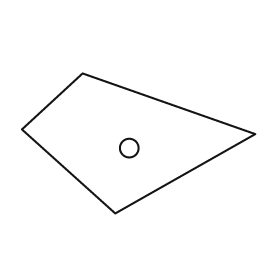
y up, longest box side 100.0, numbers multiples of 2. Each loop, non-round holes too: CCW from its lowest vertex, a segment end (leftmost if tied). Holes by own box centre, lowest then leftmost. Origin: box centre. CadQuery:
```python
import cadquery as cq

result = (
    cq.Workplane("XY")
    .moveTo(-10.0, -30.0)
    .lineTo(50.0, 4.0)
    .lineTo(-24.0, 30.0)
    .lineTo(-50.0, 6.0)
    .close()
    .moveTo(-4.0, -2.0)
    .circle(4.0)
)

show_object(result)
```